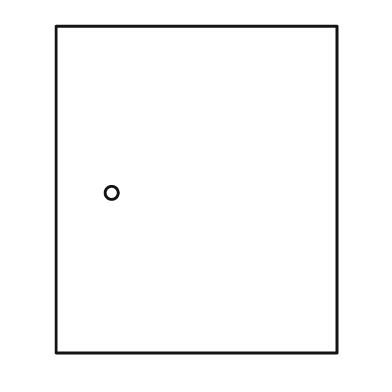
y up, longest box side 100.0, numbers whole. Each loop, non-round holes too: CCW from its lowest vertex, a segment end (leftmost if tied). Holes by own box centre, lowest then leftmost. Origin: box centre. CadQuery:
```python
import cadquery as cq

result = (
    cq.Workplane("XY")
    .moveTo(-43.0, -50.0)
    .lineTo(43.0, -50.0)
    .lineTo(43.0, 50.0)
    .lineTo(-43.0, 50.0)
    .close()
    .moveTo(-26.0, -1.0)
    .circle(2.0)
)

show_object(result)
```